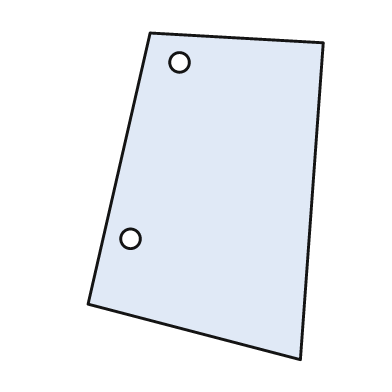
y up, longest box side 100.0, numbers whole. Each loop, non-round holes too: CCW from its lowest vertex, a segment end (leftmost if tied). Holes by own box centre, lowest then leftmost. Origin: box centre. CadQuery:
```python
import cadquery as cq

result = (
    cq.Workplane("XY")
    .moveTo(29.0, -50.0)
    .lineTo(36.0, 47.0)
    .lineTo(-17.0, 50.0)
    .lineTo(-36.0, -33.0)
    .close()
    .moveTo(-23.0, -13.0)
    .circle(3.0)
    .moveTo(-8.0, 41.0)
    .circle(3.0)
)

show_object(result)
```